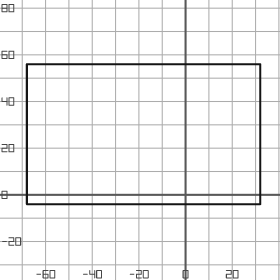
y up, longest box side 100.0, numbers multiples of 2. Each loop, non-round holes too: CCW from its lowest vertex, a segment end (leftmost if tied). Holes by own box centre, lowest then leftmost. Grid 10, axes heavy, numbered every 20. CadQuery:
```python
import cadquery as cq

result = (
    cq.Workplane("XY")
    .moveTo(-68.0, -4.0)
    .lineTo(32.0, -4.0)
    .lineTo(32.0, 56.0)
    .lineTo(-68.0, 56.0)
    .close()
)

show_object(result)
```